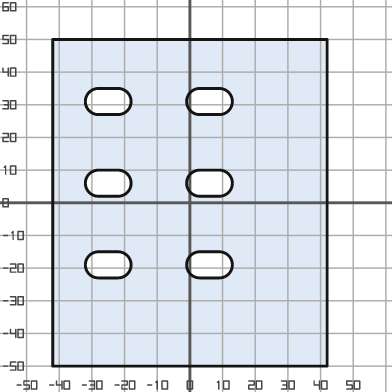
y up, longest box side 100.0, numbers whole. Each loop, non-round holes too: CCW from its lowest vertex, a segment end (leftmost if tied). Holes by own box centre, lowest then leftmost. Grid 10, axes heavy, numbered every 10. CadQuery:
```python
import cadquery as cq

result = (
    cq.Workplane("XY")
    .moveTo(-42.0, -50.0)
    .lineTo(42.0, -50.0)
    .lineTo(42.0, 50.0)
    .lineTo(-42.0, 50.0)
    .close()
    .moveTo(-28.0, -23.0)
    .lineTo(-22.0, -23.0)
    .threePointArc((-18.0, -19.0), (-22.0, -15.0))
    .lineTo(-28.0, -15.0)
    .threePointArc((-32.0, -19.0), (-28.0, -23.0))
    .close()
    .moveTo(3.0, -23.0)
    .lineTo(9.0, -23.0)
    .threePointArc((13.0, -19.0), (9.0, -15.0))
    .lineTo(3.0, -15.0)
    .threePointArc((-1.0, -19.0), (3.0, -23.0))
    .close()
    .moveTo(-28.0, 2.0)
    .lineTo(-22.0, 2.0)
    .threePointArc((-18.0, 6.0), (-22.0, 10.0))
    .lineTo(-28.0, 10.0)
    .threePointArc((-32.0, 6.0), (-28.0, 2.0))
    .close()
    .moveTo(3.0, 2.0)
    .lineTo(9.0, 2.0)
    .threePointArc((13.0, 6.0), (9.0, 10.0))
    .lineTo(3.0, 10.0)
    .threePointArc((-1.0, 6.0), (3.0, 2.0))
    .close()
    .moveTo(-28.0, 27.0)
    .lineTo(-22.0, 27.0)
    .threePointArc((-18.0, 31.0), (-22.0, 35.0))
    .lineTo(-28.0, 35.0)
    .threePointArc((-32.0, 31.0), (-28.0, 27.0))
    .close()
    .moveTo(3.0, 27.0)
    .lineTo(9.0, 27.0)
    .threePointArc((13.0, 31.0), (9.0, 35.0))
    .lineTo(3.0, 35.0)
    .threePointArc((-1.0, 31.0), (3.0, 27.0))
    .close()
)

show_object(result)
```